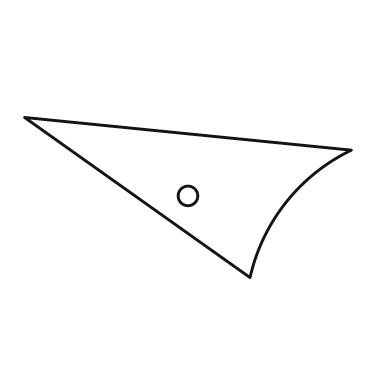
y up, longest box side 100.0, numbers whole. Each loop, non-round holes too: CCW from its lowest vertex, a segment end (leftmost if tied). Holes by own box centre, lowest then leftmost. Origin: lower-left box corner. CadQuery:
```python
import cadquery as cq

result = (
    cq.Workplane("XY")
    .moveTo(69.0, 0.0)
    .threePointArc((80.0, 23.0), (100.0, 39.0))
    .lineTo(0.0, 49.0)
    .close()
    .moveTo(50.0, 25.0)
    .circle(3.0)
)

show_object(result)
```